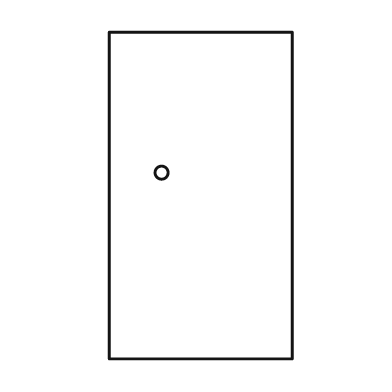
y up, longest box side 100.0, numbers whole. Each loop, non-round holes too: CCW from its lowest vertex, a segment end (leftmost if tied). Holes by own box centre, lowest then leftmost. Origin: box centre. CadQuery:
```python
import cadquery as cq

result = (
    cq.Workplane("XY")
    .moveTo(-28.0, -50.0)
    .lineTo(28.0, -50.0)
    .lineTo(28.0, 50.0)
    .lineTo(-28.0, 50.0)
    .close()
    .moveTo(-12.0, 7.0)
    .circle(2.0)
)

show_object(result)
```